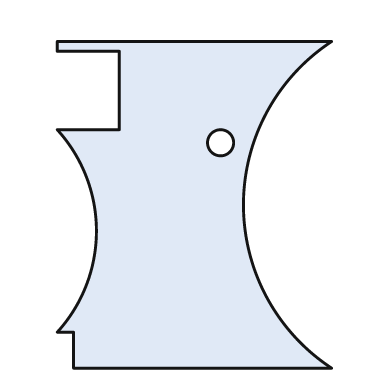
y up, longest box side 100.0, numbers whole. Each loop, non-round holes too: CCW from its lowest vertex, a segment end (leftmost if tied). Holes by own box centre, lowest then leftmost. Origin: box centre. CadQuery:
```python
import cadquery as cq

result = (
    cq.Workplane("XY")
    .moveTo(-37.0, -50.0)
    .lineTo(42.0, -50.0)
    .threePointArc((15.0, 0.0), (42.0, 50.0))
    .lineTo(-42.0, 50.0)
    .lineTo(-42.0, 47.0)
    .lineTo(-23.0, 47.0)
    .lineTo(-23.0, 23.0)
    .lineTo(-42.0, 23.0)
    .threePointArc((-30.0, -8.0), (-42.0, -39.0))
    .lineTo(-37.0, -39.0)
    .close()
    .moveTo(8.0, 19.0)
    .circle(4.0)
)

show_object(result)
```